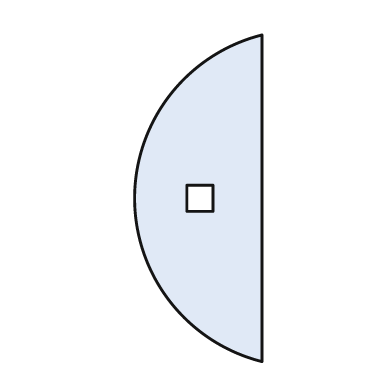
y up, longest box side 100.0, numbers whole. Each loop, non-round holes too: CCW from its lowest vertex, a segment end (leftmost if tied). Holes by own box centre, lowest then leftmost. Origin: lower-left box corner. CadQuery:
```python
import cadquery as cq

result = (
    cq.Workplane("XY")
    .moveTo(39.0, 0.0)
    .lineTo(39.0, 100.0)
    .threePointArc((0.0, 50.0), (39.0, 0.0))
    .close()
    .moveTo(16.0, 46.0)
    .lineTo(24.0, 46.0)
    .lineTo(24.0, 54.0)
    .lineTo(16.0, 54.0)
    .close()
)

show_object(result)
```